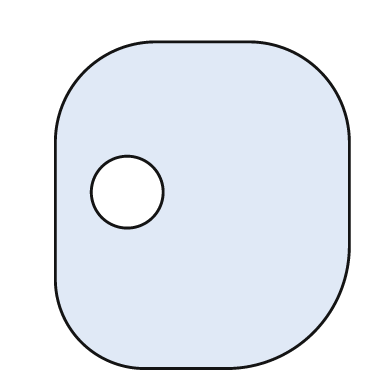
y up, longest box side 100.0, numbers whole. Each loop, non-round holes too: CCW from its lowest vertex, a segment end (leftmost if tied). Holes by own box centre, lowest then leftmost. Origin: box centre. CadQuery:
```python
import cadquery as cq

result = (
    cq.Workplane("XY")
    .moveTo(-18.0, -50.0)
    .lineTo(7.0, -50.0)
    .threePointArc((34.0, -39.0), (45.0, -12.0))
    .lineTo(45.0, 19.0)
    .threePointArc((36.0, 41.0), (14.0, 50.0))
    .lineTo(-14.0, 50.0)
    .threePointArc((-36.0, 41.0), (-45.0, 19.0))
    .lineTo(-45.0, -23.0)
    .threePointArc((-37.0, -42.0), (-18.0, -50.0))
    .close()
    .moveTo(-23.0, 4.0)
    .circle(11.0)
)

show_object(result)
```